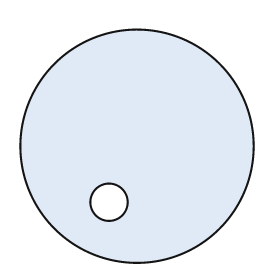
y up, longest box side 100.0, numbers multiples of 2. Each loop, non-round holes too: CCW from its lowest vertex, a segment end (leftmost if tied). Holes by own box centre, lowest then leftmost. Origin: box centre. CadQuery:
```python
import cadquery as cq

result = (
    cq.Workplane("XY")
    .moveTo(0.0, 0.0)
    .circle(50.0)
    .moveTo(-12.0, -24.0)
    .circle(8.0)
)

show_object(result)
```